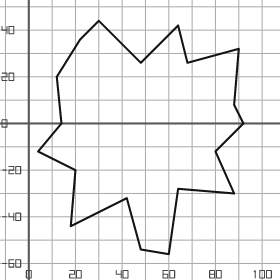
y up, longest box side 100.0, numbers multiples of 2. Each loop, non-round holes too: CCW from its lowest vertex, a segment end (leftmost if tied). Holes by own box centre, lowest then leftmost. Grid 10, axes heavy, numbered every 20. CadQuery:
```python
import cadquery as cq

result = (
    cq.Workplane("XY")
    .moveTo(60.0, -56.0)
    .lineTo(64.0, -28.0)
    .lineTo(88.0, -30.0)
    .lineTo(80.0, -12.0)
    .lineTo(92.0, 0.0)
    .lineTo(88.0, 8.0)
    .lineTo(90.0, 32.0)
    .lineTo(68.0, 26.0)
    .lineTo(64.0, 42.0)
    .lineTo(48.0, 26.0)
    .lineTo(30.0, 44.0)
    .lineTo(22.0, 36.0)
    .lineTo(12.0, 20.0)
    .lineTo(14.0, 0.0)
    .lineTo(4.0, -12.0)
    .lineTo(20.0, -20.0)
    .lineTo(18.0, -44.0)
    .lineTo(42.0, -32.0)
    .lineTo(48.0, -54.0)
    .close()
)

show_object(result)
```